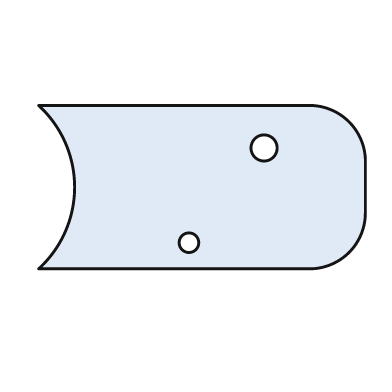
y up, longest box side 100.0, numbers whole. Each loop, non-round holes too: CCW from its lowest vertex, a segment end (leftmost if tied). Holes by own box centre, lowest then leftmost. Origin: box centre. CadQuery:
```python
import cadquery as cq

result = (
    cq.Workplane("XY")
    .moveTo(-50.0, -25.0)
    .lineTo(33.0, -25.0)
    .threePointArc((45.0, -20.0), (50.0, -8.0))
    .lineTo(50.0, 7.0)
    .threePointArc((45.0, 20.0), (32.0, 25.0))
    .lineTo(-50.0, 25.0)
    .threePointArc((-39.0, 0.0), (-50.0, -25.0))
    .close()
    .moveTo(-4.0, -17.0)
    .circle(3.0)
    .moveTo(19.0, 12.0)
    .circle(4.0)
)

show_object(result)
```